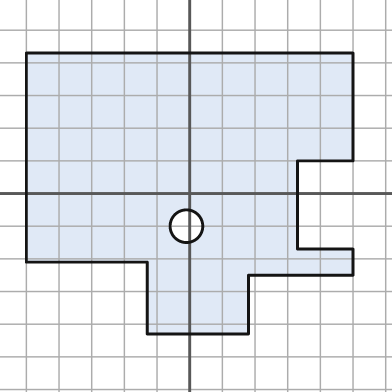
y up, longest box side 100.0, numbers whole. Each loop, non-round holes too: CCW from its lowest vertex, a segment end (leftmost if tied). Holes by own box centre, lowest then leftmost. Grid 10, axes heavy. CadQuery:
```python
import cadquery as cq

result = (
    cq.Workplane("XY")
    .moveTo(-13.0, -43.0)
    .lineTo(18.0, -43.0)
    .lineTo(18.0, -25.0)
    .lineTo(50.0, -25.0)
    .lineTo(50.0, -17.0)
    .lineTo(33.0, -17.0)
    .lineTo(33.0, 10.0)
    .lineTo(50.0, 10.0)
    .lineTo(50.0, 43.0)
    .lineTo(-50.0, 43.0)
    .lineTo(-50.0, -21.0)
    .lineTo(-13.0, -21.0)
    .close()
    .moveTo(-1.0, -10.0)
    .circle(5.0)
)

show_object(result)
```